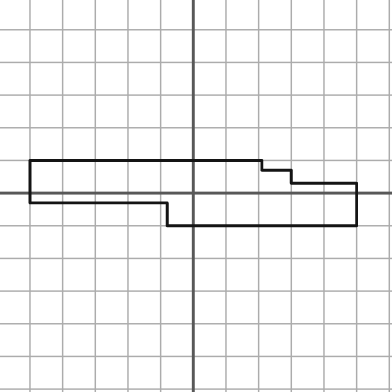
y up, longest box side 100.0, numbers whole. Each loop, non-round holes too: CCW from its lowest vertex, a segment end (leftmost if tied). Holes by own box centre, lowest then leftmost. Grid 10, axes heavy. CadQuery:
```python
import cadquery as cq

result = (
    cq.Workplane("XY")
    .moveTo(-8.0, -10.0)
    .lineTo(50.0, -10.0)
    .lineTo(50.0, 3.0)
    .lineTo(30.0, 3.0)
    .lineTo(30.0, 7.0)
    .lineTo(21.0, 7.0)
    .lineTo(21.0, 10.0)
    .lineTo(-50.0, 10.0)
    .lineTo(-50.0, -3.0)
    .lineTo(-8.0, -3.0)
    .close()
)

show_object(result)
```